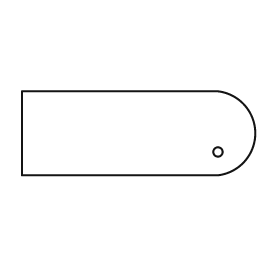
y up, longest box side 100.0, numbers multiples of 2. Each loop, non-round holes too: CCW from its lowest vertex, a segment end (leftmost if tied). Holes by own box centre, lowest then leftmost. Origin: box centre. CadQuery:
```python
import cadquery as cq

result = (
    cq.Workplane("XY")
    .moveTo(-50.0, -18.0)
    .lineTo(34.0, -18.0)
    .threePointArc((50.0, 0.0), (34.0, 18.0))
    .lineTo(-50.0, 18.0)
    .close()
    .moveTo(34.0, -8.0)
    .circle(2.0)
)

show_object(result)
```